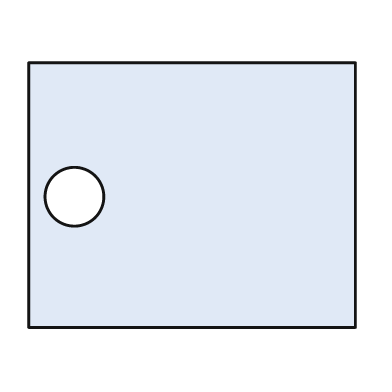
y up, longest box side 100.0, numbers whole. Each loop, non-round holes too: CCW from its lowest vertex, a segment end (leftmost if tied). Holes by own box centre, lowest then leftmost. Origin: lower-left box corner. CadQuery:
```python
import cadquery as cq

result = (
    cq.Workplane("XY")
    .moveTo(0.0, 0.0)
    .lineTo(100.0, 0.0)
    .lineTo(100.0, 81.0)
    .lineTo(0.0, 81.0)
    .close()
    .moveTo(14.0, 40.0)
    .circle(9.0)
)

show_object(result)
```